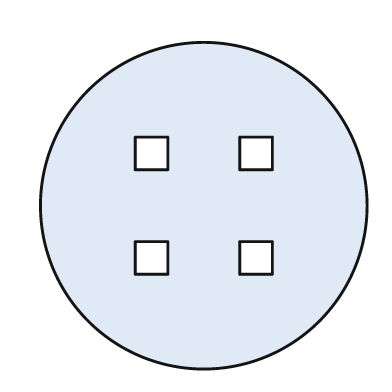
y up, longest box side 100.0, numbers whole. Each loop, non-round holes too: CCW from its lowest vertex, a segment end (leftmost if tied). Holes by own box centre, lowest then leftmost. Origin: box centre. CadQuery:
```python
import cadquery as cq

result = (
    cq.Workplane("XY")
    .moveTo(0.0, 0.0)
    .circle(50.0)
    .moveTo(-21.0, -21.0)
    .lineTo(-11.0, -21.0)
    .lineTo(-11.0, -11.0)
    .lineTo(-21.0, -11.0)
    .close()
    .moveTo(11.0, -21.0)
    .lineTo(21.0, -21.0)
    .lineTo(21.0, -11.0)
    .lineTo(11.0, -11.0)
    .close()
    .moveTo(-21.0, 11.0)
    .lineTo(-11.0, 11.0)
    .lineTo(-11.0, 21.0)
    .lineTo(-21.0, 21.0)
    .close()
    .moveTo(11.0, 11.0)
    .lineTo(21.0, 11.0)
    .lineTo(21.0, 21.0)
    .lineTo(11.0, 21.0)
    .close()
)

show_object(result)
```